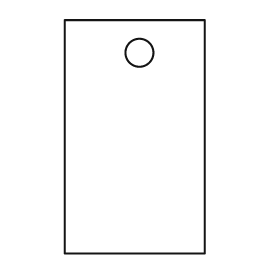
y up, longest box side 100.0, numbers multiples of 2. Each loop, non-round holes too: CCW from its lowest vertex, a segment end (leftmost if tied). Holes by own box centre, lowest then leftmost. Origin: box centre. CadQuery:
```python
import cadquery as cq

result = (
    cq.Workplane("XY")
    .moveTo(-30.0, -50.0)
    .lineTo(30.0, -50.0)
    .lineTo(30.0, 50.0)
    .lineTo(-30.0, 50.0)
    .close()
    .moveTo(2.0, 36.0)
    .circle(6.0)
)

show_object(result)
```